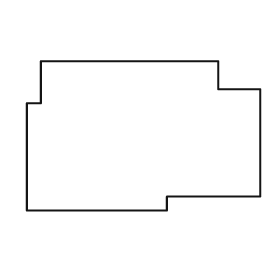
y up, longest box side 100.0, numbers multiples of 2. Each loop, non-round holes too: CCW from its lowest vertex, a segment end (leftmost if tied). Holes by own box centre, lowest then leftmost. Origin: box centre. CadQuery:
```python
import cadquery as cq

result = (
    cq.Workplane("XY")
    .moveTo(-50.0, -32.0)
    .lineTo(10.0, -32.0)
    .lineTo(10.0, -26.0)
    .lineTo(50.0, -26.0)
    .lineTo(50.0, 20.0)
    .lineTo(32.0, 20.0)
    .lineTo(32.0, 32.0)
    .lineTo(-44.0, 32.0)
    .lineTo(-44.0, 14.0)
    .lineTo(-50.0, 14.0)
    .close()
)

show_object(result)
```